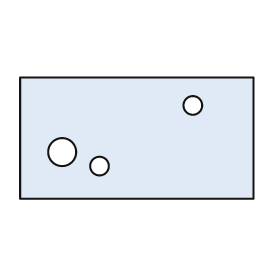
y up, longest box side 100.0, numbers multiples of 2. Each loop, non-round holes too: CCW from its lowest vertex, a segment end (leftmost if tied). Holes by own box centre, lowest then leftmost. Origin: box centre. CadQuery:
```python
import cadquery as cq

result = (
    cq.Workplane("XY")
    .moveTo(-50.0, -26.0)
    .lineTo(50.0, -26.0)
    .lineTo(50.0, 26.0)
    .lineTo(-50.0, 26.0)
    .close()
    .moveTo(-16.0, -12.0)
    .circle(4.0)
    .moveTo(-32.0, -6.0)
    .circle(6.0)
    .moveTo(24.0, 14.0)
    .circle(4.0)
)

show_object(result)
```